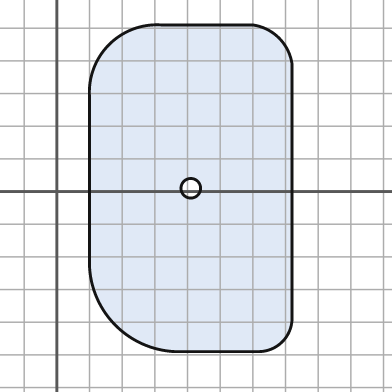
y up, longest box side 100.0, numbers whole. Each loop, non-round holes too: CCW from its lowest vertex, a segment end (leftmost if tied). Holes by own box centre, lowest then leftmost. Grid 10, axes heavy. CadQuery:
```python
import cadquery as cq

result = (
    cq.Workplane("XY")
    .moveTo(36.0, -49.0)
    .lineTo(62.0, -49.0)
    .threePointArc((69.0, -46.0), (72.0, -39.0))
    .lineTo(72.0, 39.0)
    .threePointArc((68.0, 47.0), (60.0, 51.0))
    .lineTo(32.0, 51.0)
    .threePointArc((16.0, 45.0), (10.0, 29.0))
    .lineTo(10.0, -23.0)
    .threePointArc((18.0, -41.0), (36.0, -49.0))
    .close()
    .moveTo(41.0, 1.0)
    .circle(3.0)
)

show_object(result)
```